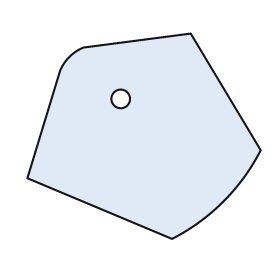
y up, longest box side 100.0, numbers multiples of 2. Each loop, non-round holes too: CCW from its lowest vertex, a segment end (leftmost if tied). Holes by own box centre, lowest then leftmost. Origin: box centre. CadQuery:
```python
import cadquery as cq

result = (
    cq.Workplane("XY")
    .moveTo(12.0, -44.0)
    .threePointArc((34.0, -28.0), (50.0, -6.0))
    .lineTo(20.0, 44.0)
    .lineTo(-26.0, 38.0)
    .threePointArc((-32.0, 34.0), (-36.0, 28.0))
    .lineTo(-50.0, -18.0)
    .close()
    .moveTo(-10.0, 16.0)
    .circle(4.0)
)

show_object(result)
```